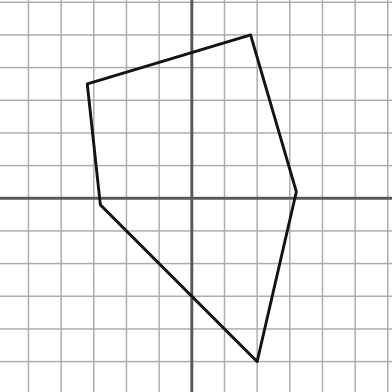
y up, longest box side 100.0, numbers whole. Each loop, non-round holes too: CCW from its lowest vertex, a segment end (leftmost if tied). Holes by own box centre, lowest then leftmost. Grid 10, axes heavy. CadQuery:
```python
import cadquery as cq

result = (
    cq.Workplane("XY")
    .moveTo(20.0, -50.0)
    .lineTo(32.0, 2.0)
    .lineTo(18.0, 50.0)
    .lineTo(-32.0, 35.0)
    .lineTo(-28.0, -2.0)
    .close()
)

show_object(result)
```